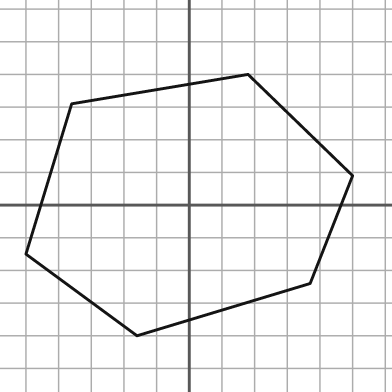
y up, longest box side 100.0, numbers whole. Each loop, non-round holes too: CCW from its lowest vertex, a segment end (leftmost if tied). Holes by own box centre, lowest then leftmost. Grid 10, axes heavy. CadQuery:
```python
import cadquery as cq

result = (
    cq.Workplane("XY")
    .moveTo(-16.0, -40.0)
    .lineTo(37.0, -24.0)
    .lineTo(50.0, 9.0)
    .lineTo(18.0, 40.0)
    .lineTo(-36.0, 31.0)
    .lineTo(-50.0, -15.0)
    .close()
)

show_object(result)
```